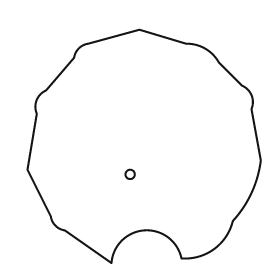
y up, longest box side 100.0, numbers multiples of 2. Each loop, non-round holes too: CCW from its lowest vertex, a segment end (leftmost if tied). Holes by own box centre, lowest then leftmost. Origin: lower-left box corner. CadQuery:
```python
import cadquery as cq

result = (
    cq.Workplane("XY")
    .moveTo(36.0, 0.0)
    .threePointArc((50.0, 14.0), (66.0, 2.0))
    .threePointArc((80.0, 6.0), (88.0, 18.0))
    .threePointArc((96.0, 30.0), (100.0, 44.0))
    .lineTo(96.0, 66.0)
    .threePointArc((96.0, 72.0), (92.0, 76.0))
    .lineTo(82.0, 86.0)
    .threePointArc((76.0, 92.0), (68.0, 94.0))
    .lineTo(48.0, 100.0)
    .lineTo(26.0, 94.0)
    .threePointArc((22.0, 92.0), (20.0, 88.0))
    .lineTo(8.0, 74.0)
    .threePointArc((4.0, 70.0), (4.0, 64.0))
    .lineTo(0.0, 40.0)
    .lineTo(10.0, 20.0)
    .threePointArc((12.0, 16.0), (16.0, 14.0))
    .close()
    .moveTo(44.0, 38.0)
    .circle(2.0)
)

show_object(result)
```